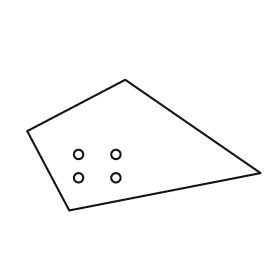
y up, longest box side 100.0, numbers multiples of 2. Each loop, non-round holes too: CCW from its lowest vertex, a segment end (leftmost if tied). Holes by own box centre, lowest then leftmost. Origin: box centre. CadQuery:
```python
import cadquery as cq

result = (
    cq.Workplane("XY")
    .moveTo(-32.0, -28.0)
    .lineTo(50.0, -12.0)
    .lineTo(-8.0, 28.0)
    .lineTo(-50.0, 6.0)
    .close()
    .moveTo(-28.0, -14.0)
    .circle(2.0)
    .moveTo(-12.0, -14.0)
    .circle(2.0)
    .moveTo(-28.0, -4.0)
    .circle(2.0)
    .moveTo(-12.0, -4.0)
    .circle(2.0)
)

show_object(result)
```